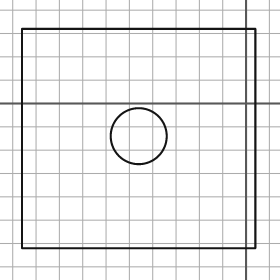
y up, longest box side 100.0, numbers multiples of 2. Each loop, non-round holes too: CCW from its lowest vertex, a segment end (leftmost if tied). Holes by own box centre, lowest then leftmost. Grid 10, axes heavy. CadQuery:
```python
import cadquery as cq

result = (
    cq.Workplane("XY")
    .moveTo(-96.0, -62.0)
    .lineTo(4.0, -62.0)
    .lineTo(4.0, 32.0)
    .lineTo(-96.0, 32.0)
    .close()
    .moveTo(-46.0, -14.0)
    .circle(12.0)
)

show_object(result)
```